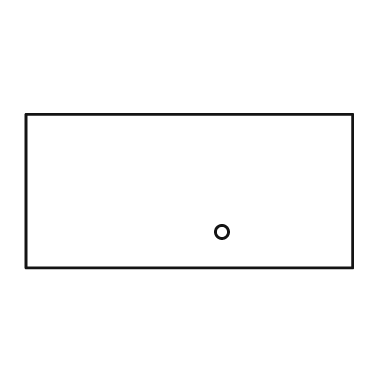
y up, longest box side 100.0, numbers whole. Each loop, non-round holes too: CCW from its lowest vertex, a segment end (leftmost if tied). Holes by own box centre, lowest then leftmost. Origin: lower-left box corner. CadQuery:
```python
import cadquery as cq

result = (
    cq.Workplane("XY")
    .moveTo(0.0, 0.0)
    .lineTo(100.0, 0.0)
    .lineTo(100.0, 47.0)
    .lineTo(0.0, 47.0)
    .close()
    .moveTo(60.0, 11.0)
    .circle(2.0)
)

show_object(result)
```